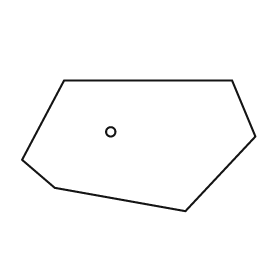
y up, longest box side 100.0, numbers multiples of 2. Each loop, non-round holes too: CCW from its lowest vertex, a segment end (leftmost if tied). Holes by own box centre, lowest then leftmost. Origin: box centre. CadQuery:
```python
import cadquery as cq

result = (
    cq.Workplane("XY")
    .moveTo(20.0, -28.0)
    .lineTo(50.0, 4.0)
    .lineTo(40.0, 28.0)
    .lineTo(-32.0, 28.0)
    .lineTo(-50.0, -6.0)
    .lineTo(-36.0, -18.0)
    .close()
    .moveTo(-12.0, 6.0)
    .circle(2.0)
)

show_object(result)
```